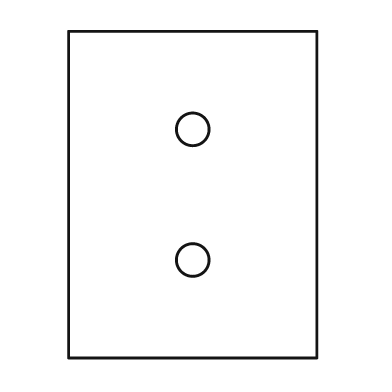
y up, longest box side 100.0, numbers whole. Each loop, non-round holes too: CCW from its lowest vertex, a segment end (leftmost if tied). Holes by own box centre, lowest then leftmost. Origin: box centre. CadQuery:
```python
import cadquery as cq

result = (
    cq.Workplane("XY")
    .moveTo(-38.0, -50.0)
    .lineTo(38.0, -50.0)
    .lineTo(38.0, 50.0)
    .lineTo(-38.0, 50.0)
    .close()
    .moveTo(0.0, -20.0)
    .circle(5.0)
    .moveTo(0.0, 20.0)
    .circle(5.0)
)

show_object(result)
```